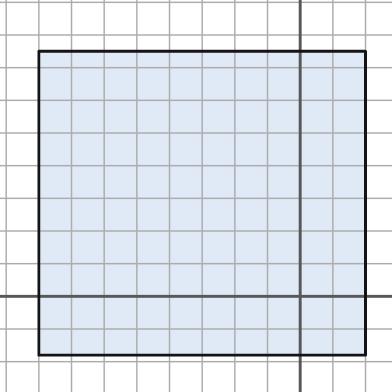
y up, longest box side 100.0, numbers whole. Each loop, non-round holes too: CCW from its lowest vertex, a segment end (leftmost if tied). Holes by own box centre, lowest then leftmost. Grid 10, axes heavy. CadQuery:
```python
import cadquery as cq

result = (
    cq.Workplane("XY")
    .moveTo(-80.0, -18.0)
    .lineTo(20.0, -18.0)
    .lineTo(20.0, 75.0)
    .lineTo(-80.0, 75.0)
    .close()
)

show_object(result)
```